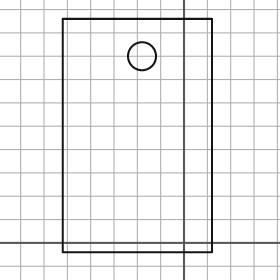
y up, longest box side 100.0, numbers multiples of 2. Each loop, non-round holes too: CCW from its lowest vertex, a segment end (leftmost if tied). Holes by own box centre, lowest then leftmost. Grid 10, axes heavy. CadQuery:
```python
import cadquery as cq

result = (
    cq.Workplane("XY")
    .moveTo(-52.0, -4.0)
    .lineTo(12.0, -4.0)
    .lineTo(12.0, 96.0)
    .lineTo(-52.0, 96.0)
    .close()
    .moveTo(-18.0, 80.0)
    .circle(6.0)
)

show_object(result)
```